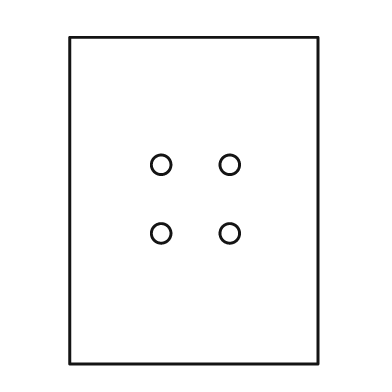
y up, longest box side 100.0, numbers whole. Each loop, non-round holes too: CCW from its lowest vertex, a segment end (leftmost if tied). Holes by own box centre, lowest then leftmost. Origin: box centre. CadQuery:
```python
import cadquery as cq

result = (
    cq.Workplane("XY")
    .moveTo(-38.0, -50.0)
    .lineTo(38.0, -50.0)
    .lineTo(38.0, 50.0)
    .lineTo(-38.0, 50.0)
    .close()
    .moveTo(-10.0, -10.0)
    .circle(3.0)
    .moveTo(11.0, -10.0)
    .circle(3.0)
    .moveTo(-10.0, 11.0)
    .circle(3.0)
    .moveTo(11.0, 11.0)
    .circle(3.0)
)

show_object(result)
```